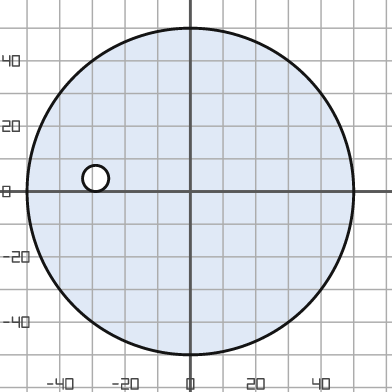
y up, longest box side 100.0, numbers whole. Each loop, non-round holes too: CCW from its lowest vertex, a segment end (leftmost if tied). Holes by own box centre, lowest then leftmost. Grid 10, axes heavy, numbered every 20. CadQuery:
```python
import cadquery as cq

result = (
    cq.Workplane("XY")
    .moveTo(0.0, 0.0)
    .circle(50.0)
    .moveTo(-29.0, 4.0)
    .circle(4.0)
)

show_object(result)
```